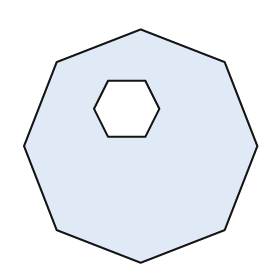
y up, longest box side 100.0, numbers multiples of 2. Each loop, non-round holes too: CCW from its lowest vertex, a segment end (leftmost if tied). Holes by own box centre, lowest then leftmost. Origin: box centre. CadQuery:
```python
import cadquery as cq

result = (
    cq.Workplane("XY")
    .moveTo(0.0, -50.0)
    .lineTo(36.0, -36.0)
    .lineTo(50.0, 0.0)
    .lineTo(36.0, 36.0)
    .lineTo(0.0, 50.0)
    .lineTo(-36.0, 36.0)
    .lineTo(-50.0, 0.0)
    .lineTo(-36.0, -36.0)
    .close()
    .moveTo(-14.0, 4.0)
    .lineTo(2.0, 4.0)
    .lineTo(8.0, 16.0)
    .lineTo(2.0, 28.0)
    .lineTo(-14.0, 28.0)
    .lineTo(-20.0, 16.0)
    .close()
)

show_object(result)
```